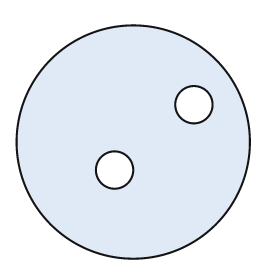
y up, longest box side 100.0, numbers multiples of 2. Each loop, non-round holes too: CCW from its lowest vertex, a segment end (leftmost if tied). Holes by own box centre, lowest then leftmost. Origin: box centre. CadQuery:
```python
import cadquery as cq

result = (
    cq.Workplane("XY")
    .moveTo(0.0, 0.0)
    .circle(50.0)
    .moveTo(-8.0, -12.0)
    .circle(8.0)
    .moveTo(26.0, 16.0)
    .circle(8.0)
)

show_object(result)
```